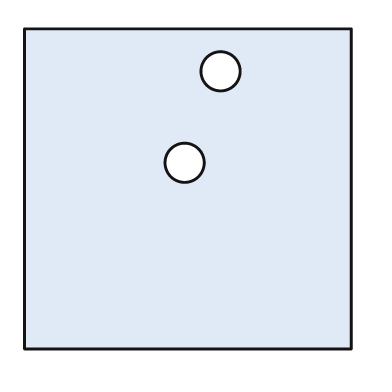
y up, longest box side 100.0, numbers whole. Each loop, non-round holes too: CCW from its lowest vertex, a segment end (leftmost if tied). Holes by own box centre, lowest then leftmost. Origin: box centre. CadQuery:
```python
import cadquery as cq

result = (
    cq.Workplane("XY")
    .moveTo(-50.0, -49.0)
    .lineTo(50.0, -49.0)
    .lineTo(50.0, 49.0)
    .lineTo(-50.0, 49.0)
    .close()
    .moveTo(-1.0, 8.0)
    .circle(6.0)
    .moveTo(10.0, 36.0)
    .circle(6.0)
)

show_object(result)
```